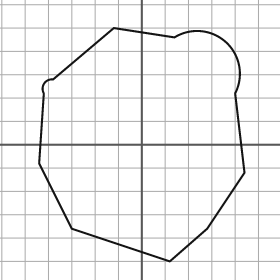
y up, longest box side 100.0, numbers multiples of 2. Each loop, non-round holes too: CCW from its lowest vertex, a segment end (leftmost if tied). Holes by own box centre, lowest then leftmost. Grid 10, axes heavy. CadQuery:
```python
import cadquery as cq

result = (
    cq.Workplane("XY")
    .moveTo(12.0, -50.0)
    .lineTo(28.0, -36.0)
    .lineTo(44.0, -12.0)
    .lineTo(40.0, 22.0)
    .threePointArc((36.0, 44.0), (14.0, 46.0))
    .lineTo(-12.0, 50.0)
    .lineTo(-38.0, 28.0)
    .threePointArc((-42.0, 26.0), (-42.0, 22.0))
    .lineTo(-44.0, -8.0)
    .lineTo(-30.0, -36.0)
    .close()
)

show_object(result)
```